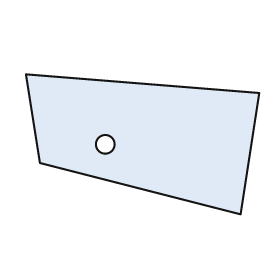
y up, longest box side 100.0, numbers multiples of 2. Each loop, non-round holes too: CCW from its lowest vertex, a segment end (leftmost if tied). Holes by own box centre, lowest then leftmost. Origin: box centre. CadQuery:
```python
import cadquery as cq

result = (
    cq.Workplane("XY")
    .moveTo(42.0, -30.0)
    .lineTo(50.0, 22.0)
    .lineTo(-50.0, 30.0)
    .lineTo(-44.0, -8.0)
    .close()
    .moveTo(-16.0, 0.0)
    .circle(4.0)
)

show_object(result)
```